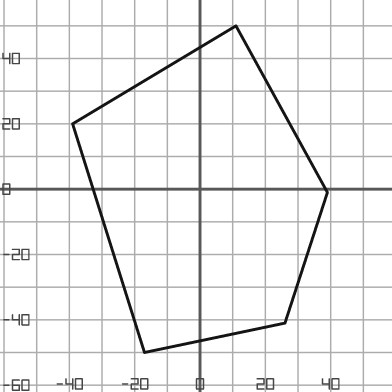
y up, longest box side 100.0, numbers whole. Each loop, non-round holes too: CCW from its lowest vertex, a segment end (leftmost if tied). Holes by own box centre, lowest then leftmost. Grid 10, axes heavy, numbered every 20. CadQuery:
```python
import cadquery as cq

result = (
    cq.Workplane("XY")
    .moveTo(-17.0, -50.0)
    .lineTo(26.0, -41.0)
    .lineTo(39.0, -1.0)
    .lineTo(11.0, 50.0)
    .lineTo(-39.0, 20.0)
    .close()
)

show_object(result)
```